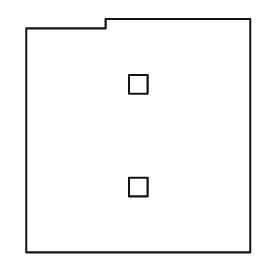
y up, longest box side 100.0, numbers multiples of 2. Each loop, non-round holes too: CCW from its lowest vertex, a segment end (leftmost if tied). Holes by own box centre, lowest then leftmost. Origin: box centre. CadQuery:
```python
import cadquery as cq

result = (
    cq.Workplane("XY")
    .moveTo(-48.0, -50.0)
    .lineTo(48.0, -50.0)
    .lineTo(48.0, 50.0)
    .lineTo(-14.0, 50.0)
    .lineTo(-14.0, 46.0)
    .lineTo(-48.0, 46.0)
    .close()
    .moveTo(-4.0, -26.0)
    .lineTo(4.0, -26.0)
    .lineTo(4.0, -18.0)
    .lineTo(-4.0, -18.0)
    .close()
    .moveTo(-4.0, 18.0)
    .lineTo(4.0, 18.0)
    .lineTo(4.0, 26.0)
    .lineTo(-4.0, 26.0)
    .close()
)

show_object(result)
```